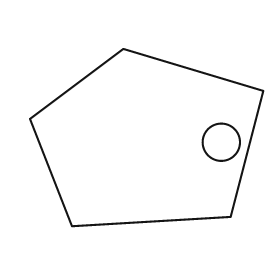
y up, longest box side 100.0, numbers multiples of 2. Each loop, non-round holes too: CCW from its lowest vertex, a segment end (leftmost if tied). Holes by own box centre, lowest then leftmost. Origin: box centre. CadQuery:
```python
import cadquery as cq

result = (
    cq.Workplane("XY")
    .moveTo(-32.0, -38.0)
    .lineTo(36.0, -34.0)
    .lineTo(50.0, 20.0)
    .lineTo(-10.0, 38.0)
    .lineTo(-50.0, 8.0)
    .close()
    .moveTo(32.0, -2.0)
    .circle(8.0)
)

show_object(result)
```